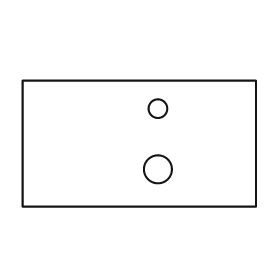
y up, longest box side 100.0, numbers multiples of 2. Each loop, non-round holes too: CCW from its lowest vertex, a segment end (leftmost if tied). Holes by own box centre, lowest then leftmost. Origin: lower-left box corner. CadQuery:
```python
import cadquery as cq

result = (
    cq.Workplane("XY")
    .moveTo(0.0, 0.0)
    .lineTo(100.0, 0.0)
    .lineTo(100.0, 54.0)
    .lineTo(0.0, 54.0)
    .close()
    .moveTo(58.0, 16.0)
    .circle(6.0)
    .moveTo(58.0, 42.0)
    .circle(4.0)
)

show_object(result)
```